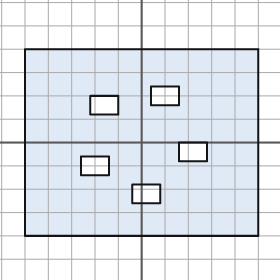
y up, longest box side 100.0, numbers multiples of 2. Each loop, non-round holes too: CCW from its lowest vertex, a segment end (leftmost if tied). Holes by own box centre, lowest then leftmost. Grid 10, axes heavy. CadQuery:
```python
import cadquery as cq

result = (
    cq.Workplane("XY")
    .moveTo(-50.0, -40.0)
    .lineTo(50.0, -40.0)
    .lineTo(50.0, 40.0)
    .lineTo(-50.0, 40.0)
    .close()
    .moveTo(-4.0, -26.0)
    .lineTo(8.0, -26.0)
    .lineTo(8.0, -18.0)
    .lineTo(-4.0, -18.0)
    .close()
    .moveTo(-26.0, -14.0)
    .lineTo(-14.0, -14.0)
    .lineTo(-14.0, -6.0)
    .lineTo(-26.0, -6.0)
    .close()
    .moveTo(16.0, -8.0)
    .lineTo(28.0, -8.0)
    .lineTo(28.0, 0.0)
    .lineTo(16.0, 0.0)
    .close()
    .moveTo(-22.0, 12.0)
    .lineTo(-10.0, 12.0)
    .lineTo(-10.0, 20.0)
    .lineTo(-22.0, 20.0)
    .close()
    .moveTo(4.0, 16.0)
    .lineTo(16.0, 16.0)
    .lineTo(16.0, 24.0)
    .lineTo(4.0, 24.0)
    .close()
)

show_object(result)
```